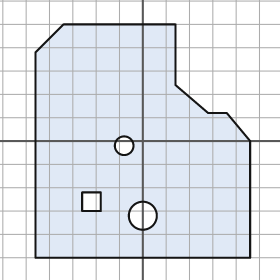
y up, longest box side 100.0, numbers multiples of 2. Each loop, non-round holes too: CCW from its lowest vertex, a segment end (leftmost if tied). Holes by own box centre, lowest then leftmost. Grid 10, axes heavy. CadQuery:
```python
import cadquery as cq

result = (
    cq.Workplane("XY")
    .moveTo(-46.0, -50.0)
    .lineTo(46.0, -50.0)
    .lineTo(46.0, 0.0)
    .lineTo(36.0, 12.0)
    .lineTo(28.0, 12.0)
    .lineTo(14.0, 24.0)
    .lineTo(14.0, 50.0)
    .lineTo(-34.0, 50.0)
    .lineTo(-46.0, 38.0)
    .close()
    .moveTo(0.0, -32.0)
    .circle(6.0)
    .moveTo(-26.0, -30.0)
    .lineTo(-18.0, -30.0)
    .lineTo(-18.0, -22.0)
    .lineTo(-26.0, -22.0)
    .close()
    .moveTo(-8.0, -2.0)
    .circle(4.0)
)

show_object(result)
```